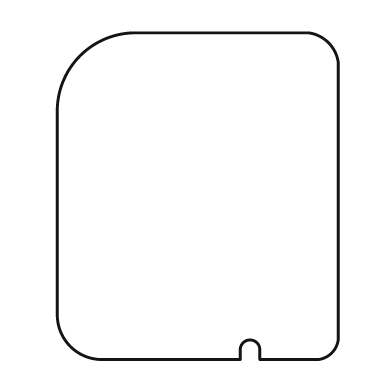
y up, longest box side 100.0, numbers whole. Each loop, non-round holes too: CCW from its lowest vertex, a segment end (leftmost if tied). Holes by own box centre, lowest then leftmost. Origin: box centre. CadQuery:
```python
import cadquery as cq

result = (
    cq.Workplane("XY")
    .moveTo(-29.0, -50.0)
    .lineTo(13.0, -50.0)
    .lineTo(13.0, -47.0)
    .threePointArc((16.0, -44.0), (19.0, -47.0))
    .lineTo(19.0, -50.0)
    .lineTo(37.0, -50.0)
    .threePointArc((41.0, -48.0), (43.0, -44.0))
    .lineTo(43.0, 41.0)
    .threePointArc((40.0, 47.0), (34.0, 50.0))
    .lineTo(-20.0, 50.0)
    .threePointArc((-36.0, 43.0), (-43.0, 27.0))
    .lineTo(-43.0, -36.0)
    .threePointArc((-39.0, -46.0), (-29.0, -50.0))
    .close()
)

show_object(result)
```